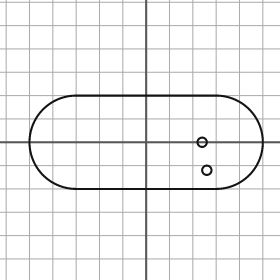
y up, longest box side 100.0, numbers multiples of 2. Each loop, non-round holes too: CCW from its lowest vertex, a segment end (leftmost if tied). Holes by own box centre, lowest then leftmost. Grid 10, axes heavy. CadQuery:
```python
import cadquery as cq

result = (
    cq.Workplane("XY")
    .moveTo(-30.0, -20.0)
    .lineTo(30.0, -20.0)
    .threePointArc((50.0, 0.0), (30.0, 20.0))
    .lineTo(-30.0, 20.0)
    .threePointArc((-50.0, 0.0), (-30.0, -20.0))
    .close()
    .moveTo(26.0, -12.0)
    .circle(2.0)
    .moveTo(24.0, 0.0)
    .circle(2.0)
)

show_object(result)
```